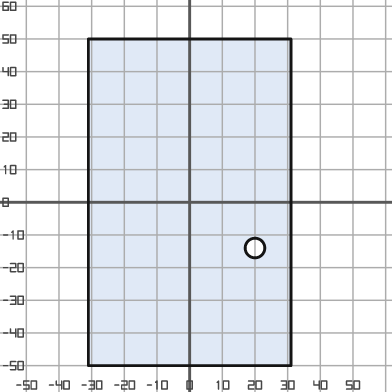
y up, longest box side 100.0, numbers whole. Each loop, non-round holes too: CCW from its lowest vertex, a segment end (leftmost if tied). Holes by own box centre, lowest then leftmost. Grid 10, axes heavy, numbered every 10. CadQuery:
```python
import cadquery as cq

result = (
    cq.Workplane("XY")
    .moveTo(-31.0, -50.0)
    .lineTo(31.0, -50.0)
    .lineTo(31.0, 50.0)
    .lineTo(-31.0, 50.0)
    .close()
    .moveTo(20.0, -14.0)
    .circle(3.0)
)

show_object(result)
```